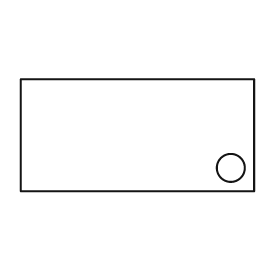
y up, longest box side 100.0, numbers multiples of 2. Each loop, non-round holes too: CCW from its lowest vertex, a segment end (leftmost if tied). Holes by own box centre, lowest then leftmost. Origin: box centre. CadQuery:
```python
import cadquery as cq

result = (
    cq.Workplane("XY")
    .moveTo(-50.0, -24.0)
    .lineTo(50.0, -24.0)
    .lineTo(50.0, 24.0)
    .lineTo(-50.0, 24.0)
    .close()
    .moveTo(40.0, -14.0)
    .circle(6.0)
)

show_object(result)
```